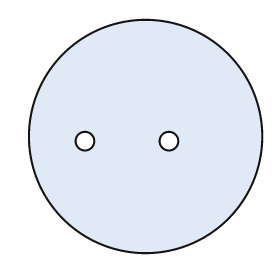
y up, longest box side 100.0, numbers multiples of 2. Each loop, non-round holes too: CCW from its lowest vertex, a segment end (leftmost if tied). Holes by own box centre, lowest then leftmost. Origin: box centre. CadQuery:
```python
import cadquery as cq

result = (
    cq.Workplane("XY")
    .moveTo(0.0, 0.0)
    .circle(50.0)
    .moveTo(-26.0, -2.0)
    .circle(4.0)
    .moveTo(10.0, -2.0)
    .circle(4.0)
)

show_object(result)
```